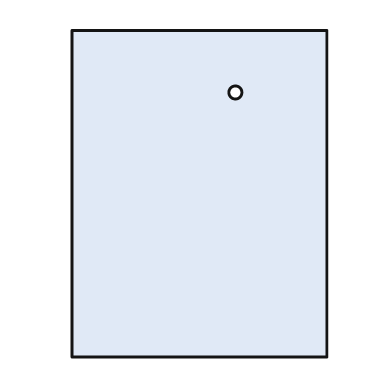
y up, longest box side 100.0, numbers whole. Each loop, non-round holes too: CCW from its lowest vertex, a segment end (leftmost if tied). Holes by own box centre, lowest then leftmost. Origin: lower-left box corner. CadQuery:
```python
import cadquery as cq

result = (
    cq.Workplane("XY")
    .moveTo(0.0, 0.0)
    .lineTo(78.0, 0.0)
    .lineTo(78.0, 100.0)
    .lineTo(0.0, 100.0)
    .close()
    .moveTo(50.0, 81.0)
    .circle(2.0)
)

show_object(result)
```